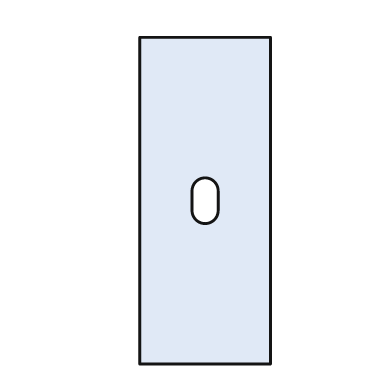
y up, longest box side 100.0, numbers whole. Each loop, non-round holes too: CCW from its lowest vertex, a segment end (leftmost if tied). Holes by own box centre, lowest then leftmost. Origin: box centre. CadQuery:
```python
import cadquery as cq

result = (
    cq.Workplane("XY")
    .moveTo(-20.0, -50.0)
    .lineTo(20.0, -50.0)
    .lineTo(20.0, 50.0)
    .lineTo(-20.0, 50.0)
    .close()
    .moveTo(-4.0, -3.0)
    .threePointArc((0.0, -7.0), (4.0, -3.0))
    .lineTo(4.0, 3.0)
    .threePointArc((0.0, 7.0), (-4.0, 3.0))
    .close()
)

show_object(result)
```